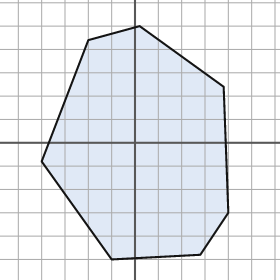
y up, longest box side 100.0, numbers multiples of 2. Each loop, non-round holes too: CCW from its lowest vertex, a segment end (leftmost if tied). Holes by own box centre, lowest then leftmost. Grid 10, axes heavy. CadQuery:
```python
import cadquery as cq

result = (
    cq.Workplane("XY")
    .moveTo(-10.0, -50.0)
    .lineTo(28.0, -48.0)
    .lineTo(40.0, -30.0)
    .lineTo(38.0, 24.0)
    .lineTo(2.0, 50.0)
    .lineTo(-20.0, 44.0)
    .lineTo(-40.0, -8.0)
    .close()
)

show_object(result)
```